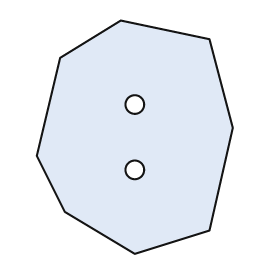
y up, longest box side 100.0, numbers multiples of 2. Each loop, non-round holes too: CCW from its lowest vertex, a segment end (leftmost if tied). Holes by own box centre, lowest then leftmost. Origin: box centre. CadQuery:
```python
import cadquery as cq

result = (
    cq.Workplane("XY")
    .moveTo(0.0, -50.0)
    .lineTo(32.0, -40.0)
    .lineTo(42.0, 4.0)
    .lineTo(32.0, 42.0)
    .lineTo(-6.0, 50.0)
    .lineTo(-32.0, 34.0)
    .lineTo(-42.0, -8.0)
    .lineTo(-30.0, -32.0)
    .close()
    .moveTo(0.0, -14.0)
    .circle(4.0)
    .moveTo(0.0, 14.0)
    .circle(4.0)
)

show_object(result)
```